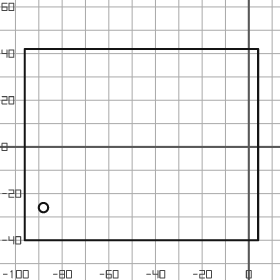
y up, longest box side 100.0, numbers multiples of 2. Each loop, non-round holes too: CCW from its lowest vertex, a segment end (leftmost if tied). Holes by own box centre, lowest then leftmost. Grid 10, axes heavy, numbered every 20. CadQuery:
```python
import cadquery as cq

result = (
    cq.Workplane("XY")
    .moveTo(-96.0, -40.0)
    .lineTo(4.0, -40.0)
    .lineTo(4.0, 42.0)
    .lineTo(-96.0, 42.0)
    .close()
    .moveTo(-88.0, -26.0)
    .circle(2.0)
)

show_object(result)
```